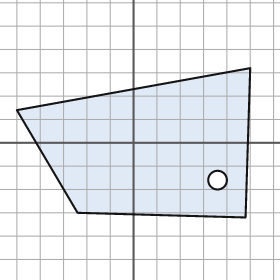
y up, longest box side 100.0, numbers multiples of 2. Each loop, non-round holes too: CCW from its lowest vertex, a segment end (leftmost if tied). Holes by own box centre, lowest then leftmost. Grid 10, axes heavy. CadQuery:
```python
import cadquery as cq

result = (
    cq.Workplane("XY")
    .moveTo(48.0, -32.0)
    .lineTo(50.0, 32.0)
    .lineTo(-50.0, 14.0)
    .lineTo(-24.0, -30.0)
    .close()
    .moveTo(36.0, -16.0)
    .circle(4.0)
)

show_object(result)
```